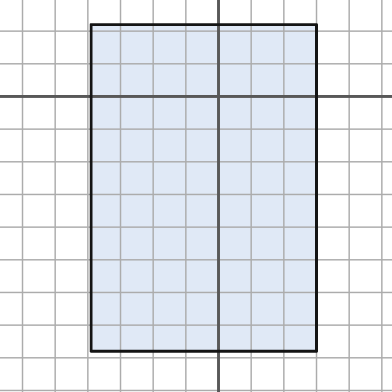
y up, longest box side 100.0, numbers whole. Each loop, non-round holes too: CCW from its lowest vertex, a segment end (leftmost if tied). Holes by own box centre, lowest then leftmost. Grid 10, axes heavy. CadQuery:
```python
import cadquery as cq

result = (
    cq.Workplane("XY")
    .moveTo(-39.0, -78.0)
    .lineTo(30.0, -78.0)
    .lineTo(30.0, 22.0)
    .lineTo(-39.0, 22.0)
    .close()
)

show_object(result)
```